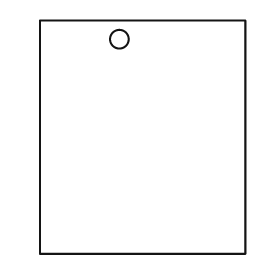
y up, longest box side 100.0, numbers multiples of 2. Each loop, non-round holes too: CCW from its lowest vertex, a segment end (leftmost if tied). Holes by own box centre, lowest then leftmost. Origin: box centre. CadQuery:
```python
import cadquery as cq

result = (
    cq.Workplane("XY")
    .moveTo(-44.0, -50.0)
    .lineTo(44.0, -50.0)
    .lineTo(44.0, 50.0)
    .lineTo(-44.0, 50.0)
    .close()
    .moveTo(-10.0, 42.0)
    .circle(4.0)
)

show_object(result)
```